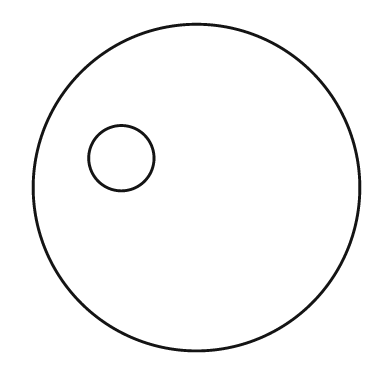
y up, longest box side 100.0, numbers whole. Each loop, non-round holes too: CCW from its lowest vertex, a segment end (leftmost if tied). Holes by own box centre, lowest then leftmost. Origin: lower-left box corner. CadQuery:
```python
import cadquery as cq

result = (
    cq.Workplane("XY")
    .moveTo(50.0, 50.0)
    .circle(50.0)
    .moveTo(27.0, 59.0)
    .circle(10.0)
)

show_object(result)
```